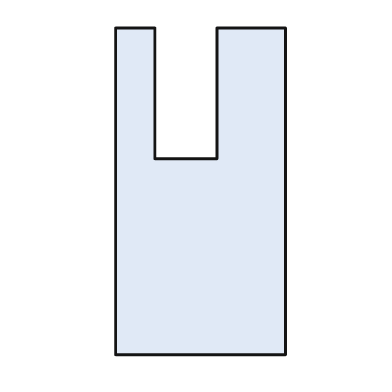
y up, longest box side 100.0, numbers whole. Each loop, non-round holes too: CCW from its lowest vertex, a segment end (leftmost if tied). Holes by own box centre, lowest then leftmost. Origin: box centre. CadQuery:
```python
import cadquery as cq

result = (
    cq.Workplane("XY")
    .moveTo(-26.0, -50.0)
    .lineTo(26.0, -50.0)
    .lineTo(26.0, 50.0)
    .lineTo(5.0, 50.0)
    .lineTo(5.0, 10.0)
    .lineTo(-14.0, 10.0)
    .lineTo(-14.0, 50.0)
    .lineTo(-26.0, 50.0)
    .close()
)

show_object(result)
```